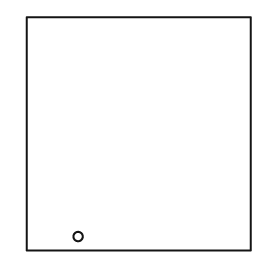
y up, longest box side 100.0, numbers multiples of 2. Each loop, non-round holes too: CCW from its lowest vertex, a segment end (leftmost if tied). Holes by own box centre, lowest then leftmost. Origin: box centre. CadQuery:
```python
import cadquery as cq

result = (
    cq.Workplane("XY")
    .moveTo(-48.0, -50.0)
    .lineTo(48.0, -50.0)
    .lineTo(48.0, 50.0)
    .lineTo(-48.0, 50.0)
    .close()
    .moveTo(-26.0, -44.0)
    .circle(2.0)
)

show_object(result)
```